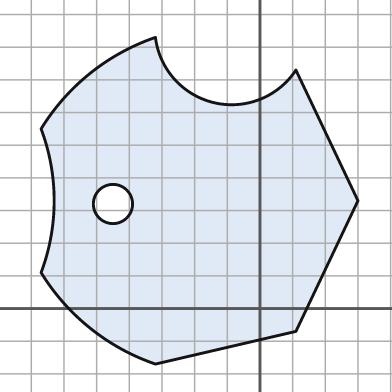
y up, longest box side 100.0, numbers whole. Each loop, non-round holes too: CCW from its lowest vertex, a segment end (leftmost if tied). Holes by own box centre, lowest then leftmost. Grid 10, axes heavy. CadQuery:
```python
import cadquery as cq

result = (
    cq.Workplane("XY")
    .moveTo(-32.0, -17.0)
    .lineTo(11.0, -7.0)
    .lineTo(30.0, 33.0)
    .lineTo(11.0, 73.0)
    .threePointArc((-14.0, 63.0), (-32.0, 83.0))
    .threePointArc((-52.0, 72.0), (-67.0, 55.0))
    .threePointArc((-63.0, 33.0), (-67.0, 11.0))
    .threePointArc((-52.0, -6.0), (-32.0, -17.0))
    .close()
    .moveTo(-45.0, 32.0)
    .circle(6.0)
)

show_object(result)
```